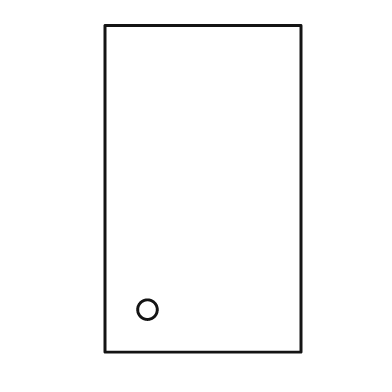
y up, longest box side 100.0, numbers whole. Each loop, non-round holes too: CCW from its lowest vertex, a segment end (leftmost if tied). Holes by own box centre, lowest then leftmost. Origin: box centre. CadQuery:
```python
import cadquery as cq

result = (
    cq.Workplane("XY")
    .moveTo(-30.0, -50.0)
    .lineTo(30.0, -50.0)
    .lineTo(30.0, 50.0)
    .lineTo(-30.0, 50.0)
    .close()
    .moveTo(-17.0, -37.0)
    .circle(3.0)
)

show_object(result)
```